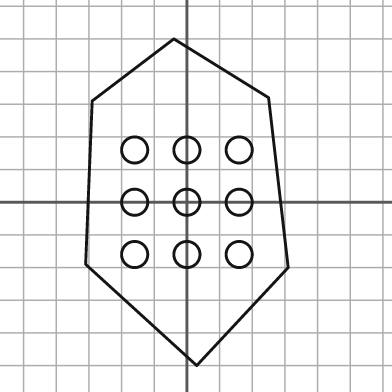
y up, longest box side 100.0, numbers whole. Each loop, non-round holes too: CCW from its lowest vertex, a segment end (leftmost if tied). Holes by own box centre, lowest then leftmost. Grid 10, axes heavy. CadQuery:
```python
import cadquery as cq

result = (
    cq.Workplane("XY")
    .moveTo(3.0, -50.0)
    .lineTo(31.0, -20.0)
    .lineTo(25.0, 32.0)
    .lineTo(-4.0, 50.0)
    .lineTo(-29.0, 31.0)
    .lineTo(-31.0, -19.0)
    .close()
    .moveTo(-16.0, -16.0)
    .circle(4.0)
    .moveTo(0.0, -16.0)
    .circle(4.0)
    .moveTo(16.0, -16.0)
    .circle(4.0)
    .moveTo(-16.0, 0.0)
    .circle(4.0)
    .moveTo(0.0, 0.0)
    .circle(4.0)
    .moveTo(16.0, 0.0)
    .circle(4.0)
    .moveTo(-16.0, 16.0)
    .circle(4.0)
    .moveTo(0.0, 16.0)
    .circle(4.0)
    .moveTo(16.0, 16.0)
    .circle(4.0)
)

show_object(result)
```